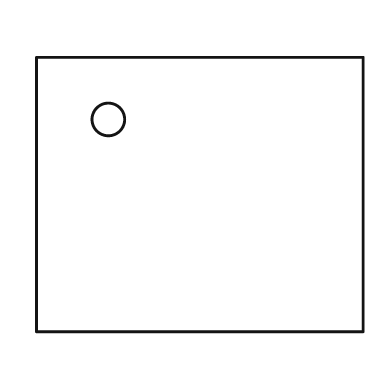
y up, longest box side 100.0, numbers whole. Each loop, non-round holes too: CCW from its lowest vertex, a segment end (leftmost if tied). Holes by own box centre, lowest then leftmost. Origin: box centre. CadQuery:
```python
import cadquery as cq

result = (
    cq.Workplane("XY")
    .moveTo(-50.0, -42.0)
    .lineTo(50.0, -42.0)
    .lineTo(50.0, 42.0)
    .lineTo(-50.0, 42.0)
    .close()
    .moveTo(-28.0, 23.0)
    .circle(5.0)
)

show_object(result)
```